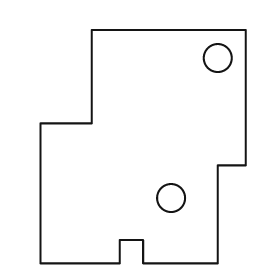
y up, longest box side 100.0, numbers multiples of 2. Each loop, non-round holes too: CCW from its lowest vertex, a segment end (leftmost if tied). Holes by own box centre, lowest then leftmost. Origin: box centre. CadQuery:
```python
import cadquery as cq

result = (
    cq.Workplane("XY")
    .moveTo(-44.0, -50.0)
    .lineTo(-10.0, -50.0)
    .lineTo(-10.0, -40.0)
    .lineTo(0.0, -40.0)
    .lineTo(0.0, -50.0)
    .lineTo(32.0, -50.0)
    .lineTo(32.0, -8.0)
    .lineTo(44.0, -8.0)
    .lineTo(44.0, 50.0)
    .lineTo(-22.0, 50.0)
    .lineTo(-22.0, 10.0)
    .lineTo(-44.0, 10.0)
    .close()
    .moveTo(12.0, -22.0)
    .circle(6.0)
    .moveTo(32.0, 38.0)
    .circle(6.0)
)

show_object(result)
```